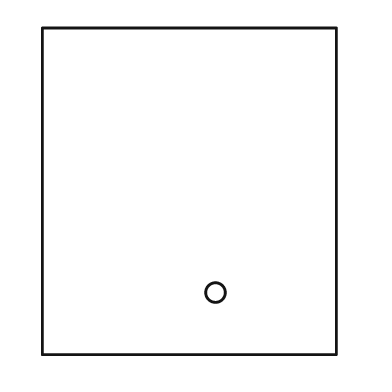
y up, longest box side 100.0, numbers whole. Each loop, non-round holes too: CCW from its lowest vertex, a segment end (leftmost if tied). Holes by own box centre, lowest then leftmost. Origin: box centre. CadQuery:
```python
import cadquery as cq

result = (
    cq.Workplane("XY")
    .moveTo(-45.0, -50.0)
    .lineTo(45.0, -50.0)
    .lineTo(45.0, 50.0)
    .lineTo(-45.0, 50.0)
    .close()
    .moveTo(8.0, -31.0)
    .circle(3.0)
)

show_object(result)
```